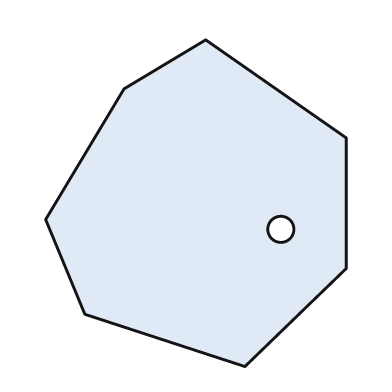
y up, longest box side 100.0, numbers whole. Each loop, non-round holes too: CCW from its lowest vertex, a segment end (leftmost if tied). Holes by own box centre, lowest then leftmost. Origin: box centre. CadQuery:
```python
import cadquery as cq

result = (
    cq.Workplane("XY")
    .moveTo(15.0, -50.0)
    .lineTo(46.0, -20.0)
    .lineTo(46.0, 20.0)
    .lineTo(3.0, 50.0)
    .lineTo(-22.0, 35.0)
    .lineTo(-46.0, -5.0)
    .lineTo(-34.0, -34.0)
    .close()
    .moveTo(26.0, -8.0)
    .circle(4.0)
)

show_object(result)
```